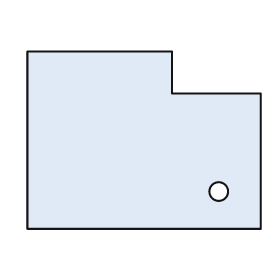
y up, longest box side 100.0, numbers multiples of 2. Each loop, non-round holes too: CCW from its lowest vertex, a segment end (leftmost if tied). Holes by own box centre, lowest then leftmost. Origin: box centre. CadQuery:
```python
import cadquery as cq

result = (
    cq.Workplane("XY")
    .moveTo(-50.0, -38.0)
    .lineTo(50.0, -38.0)
    .lineTo(50.0, 20.0)
    .lineTo(12.0, 20.0)
    .lineTo(12.0, 38.0)
    .lineTo(-50.0, 38.0)
    .close()
    .moveTo(32.0, -22.0)
    .circle(4.0)
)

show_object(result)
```